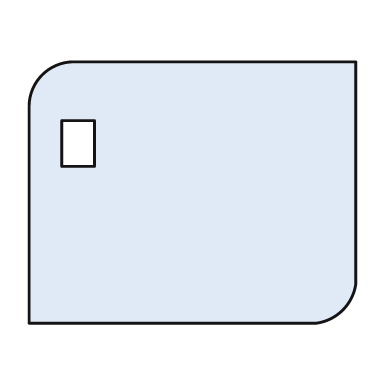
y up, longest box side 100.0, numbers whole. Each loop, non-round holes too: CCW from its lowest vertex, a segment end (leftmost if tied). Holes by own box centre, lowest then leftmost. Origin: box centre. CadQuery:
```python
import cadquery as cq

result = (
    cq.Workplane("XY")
    .moveTo(-50.0, -40.0)
    .lineTo(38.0, -40.0)
    .threePointArc((46.0, -36.0), (50.0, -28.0))
    .lineTo(50.0, 40.0)
    .lineTo(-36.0, 40.0)
    .threePointArc((-46.0, 36.0), (-50.0, 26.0))
    .close()
    .moveTo(-40.0, 8.0)
    .lineTo(-30.0, 8.0)
    .lineTo(-30.0, 22.0)
    .lineTo(-40.0, 22.0)
    .close()
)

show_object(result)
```